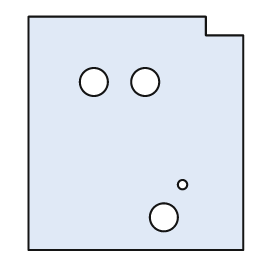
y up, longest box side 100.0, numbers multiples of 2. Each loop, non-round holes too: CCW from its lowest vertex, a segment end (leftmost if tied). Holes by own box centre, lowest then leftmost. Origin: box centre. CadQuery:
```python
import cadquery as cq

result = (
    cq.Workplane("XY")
    .moveTo(-46.0, -50.0)
    .lineTo(46.0, -50.0)
    .lineTo(46.0, 42.0)
    .lineTo(30.0, 42.0)
    .lineTo(30.0, 50.0)
    .lineTo(-46.0, 50.0)
    .close()
    .moveTo(12.0, -36.0)
    .circle(6.0)
    .moveTo(20.0, -22.0)
    .circle(2.0)
    .moveTo(-18.0, 22.0)
    .circle(6.0)
    .moveTo(4.0, 22.0)
    .circle(6.0)
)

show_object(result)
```